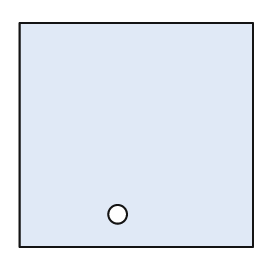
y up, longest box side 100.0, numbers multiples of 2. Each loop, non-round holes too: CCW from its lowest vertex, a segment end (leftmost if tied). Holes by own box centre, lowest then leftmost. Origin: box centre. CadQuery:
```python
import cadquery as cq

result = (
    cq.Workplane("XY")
    .moveTo(-50.0, -48.0)
    .lineTo(50.0, -48.0)
    .lineTo(50.0, 48.0)
    .lineTo(-50.0, 48.0)
    .close()
    .moveTo(-8.0, -34.0)
    .circle(4.0)
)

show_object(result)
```